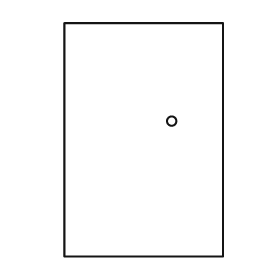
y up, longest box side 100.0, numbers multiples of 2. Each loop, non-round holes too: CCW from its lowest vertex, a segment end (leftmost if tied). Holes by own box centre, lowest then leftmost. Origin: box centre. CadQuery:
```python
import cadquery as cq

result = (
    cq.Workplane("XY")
    .moveTo(-34.0, -50.0)
    .lineTo(34.0, -50.0)
    .lineTo(34.0, 50.0)
    .lineTo(-34.0, 50.0)
    .close()
    .moveTo(12.0, 8.0)
    .circle(2.0)
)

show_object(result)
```